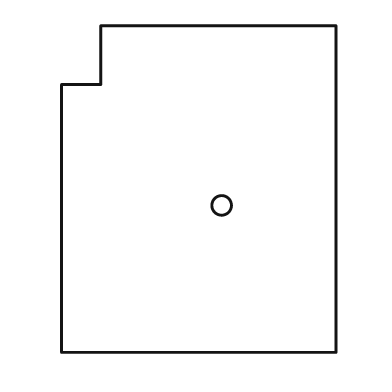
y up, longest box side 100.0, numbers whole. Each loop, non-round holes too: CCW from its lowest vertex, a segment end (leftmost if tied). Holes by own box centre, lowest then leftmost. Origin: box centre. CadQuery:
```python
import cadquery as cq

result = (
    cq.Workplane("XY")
    .moveTo(-42.0, -50.0)
    .lineTo(42.0, -50.0)
    .lineTo(42.0, 50.0)
    .lineTo(-30.0, 50.0)
    .lineTo(-30.0, 32.0)
    .lineTo(-42.0, 32.0)
    .close()
    .moveTo(7.0, -5.0)
    .circle(3.0)
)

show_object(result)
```